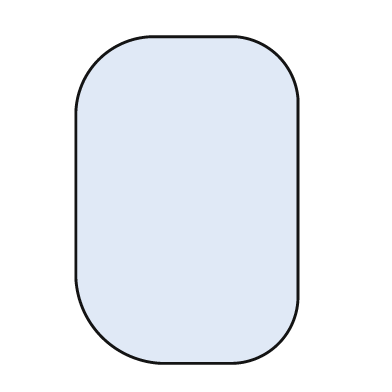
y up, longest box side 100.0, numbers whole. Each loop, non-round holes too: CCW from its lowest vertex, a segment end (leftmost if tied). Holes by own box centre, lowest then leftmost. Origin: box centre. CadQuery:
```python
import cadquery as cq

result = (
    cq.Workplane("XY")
    .moveTo(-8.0, -50.0)
    .lineTo(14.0, -50.0)
    .threePointArc((28.0, -44.0), (34.0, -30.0))
    .lineTo(34.0, 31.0)
    .threePointArc((28.0, 44.0), (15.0, 50.0))
    .lineTo(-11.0, 50.0)
    .threePointArc((-27.0, 43.0), (-34.0, 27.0))
    .lineTo(-34.0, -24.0)
    .threePointArc((-26.0, -42.0), (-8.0, -50.0))
    .close()
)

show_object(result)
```